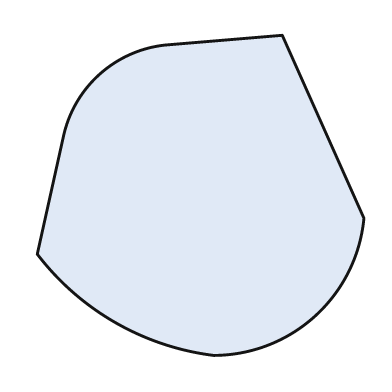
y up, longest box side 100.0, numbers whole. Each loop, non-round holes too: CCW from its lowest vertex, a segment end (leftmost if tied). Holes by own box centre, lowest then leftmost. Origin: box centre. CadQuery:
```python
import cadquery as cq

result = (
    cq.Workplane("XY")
    .moveTo(4.0, -49.0)
    .threePointArc((35.0, -37.0), (50.0, -7.0))
    .lineTo(25.0, 49.0)
    .lineTo(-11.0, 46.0)
    .threePointArc((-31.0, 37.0), (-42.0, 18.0))
    .lineTo(-50.0, -18.0)
    .threePointArc((-26.0, -39.0), (4.0, -49.0))
    .close()
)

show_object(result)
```